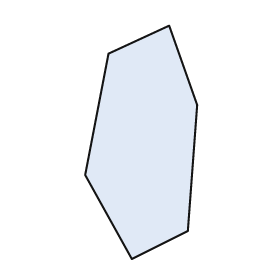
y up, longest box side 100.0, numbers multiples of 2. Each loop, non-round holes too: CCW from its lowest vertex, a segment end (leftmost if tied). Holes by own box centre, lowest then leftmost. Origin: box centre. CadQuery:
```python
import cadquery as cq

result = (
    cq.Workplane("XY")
    .moveTo(-4.0, -50.0)
    .lineTo(20.0, -38.0)
    .lineTo(24.0, 16.0)
    .lineTo(12.0, 50.0)
    .lineTo(-14.0, 38.0)
    .lineTo(-24.0, -14.0)
    .close()
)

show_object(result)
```